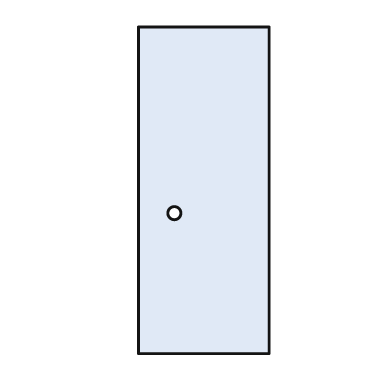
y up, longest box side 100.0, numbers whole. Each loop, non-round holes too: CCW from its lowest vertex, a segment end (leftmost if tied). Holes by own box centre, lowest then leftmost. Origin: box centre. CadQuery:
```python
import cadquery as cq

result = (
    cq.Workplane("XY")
    .moveTo(-20.0, -50.0)
    .lineTo(20.0, -50.0)
    .lineTo(20.0, 50.0)
    .lineTo(-20.0, 50.0)
    .close()
    .moveTo(-9.0, -7.0)
    .circle(2.0)
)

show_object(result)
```